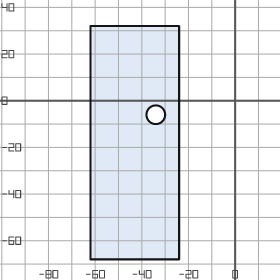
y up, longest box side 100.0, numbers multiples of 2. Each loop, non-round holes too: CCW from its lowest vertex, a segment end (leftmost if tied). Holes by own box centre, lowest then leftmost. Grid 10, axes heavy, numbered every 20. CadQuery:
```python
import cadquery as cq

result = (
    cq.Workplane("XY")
    .moveTo(-62.0, -68.0)
    .lineTo(-24.0, -68.0)
    .lineTo(-24.0, 32.0)
    .lineTo(-62.0, 32.0)
    .close()
    .moveTo(-34.0, -6.0)
    .circle(4.0)
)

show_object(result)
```